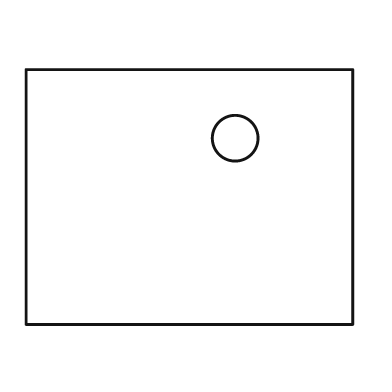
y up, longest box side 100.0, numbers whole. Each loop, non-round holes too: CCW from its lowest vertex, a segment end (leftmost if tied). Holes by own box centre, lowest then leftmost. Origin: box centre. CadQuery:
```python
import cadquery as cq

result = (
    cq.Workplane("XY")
    .moveTo(-50.0, -39.0)
    .lineTo(50.0, -39.0)
    .lineTo(50.0, 39.0)
    .lineTo(-50.0, 39.0)
    .close()
    .moveTo(14.0, 18.0)
    .circle(7.0)
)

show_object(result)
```